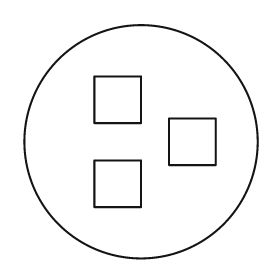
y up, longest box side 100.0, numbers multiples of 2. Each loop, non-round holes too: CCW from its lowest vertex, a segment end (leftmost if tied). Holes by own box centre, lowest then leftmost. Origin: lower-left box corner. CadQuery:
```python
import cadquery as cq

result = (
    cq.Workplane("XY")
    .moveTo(50.0, 50.0)
    .circle(50.0)
    .moveTo(30.0, 22.0)
    .lineTo(50.0, 22.0)
    .lineTo(50.0, 42.0)
    .lineTo(30.0, 42.0)
    .close()
    .moveTo(62.0, 40.0)
    .lineTo(82.0, 40.0)
    .lineTo(82.0, 60.0)
    .lineTo(62.0, 60.0)
    .close()
    .moveTo(30.0, 58.0)
    .lineTo(50.0, 58.0)
    .lineTo(50.0, 78.0)
    .lineTo(30.0, 78.0)
    .close()
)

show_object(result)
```